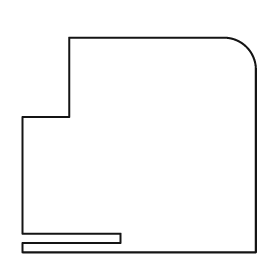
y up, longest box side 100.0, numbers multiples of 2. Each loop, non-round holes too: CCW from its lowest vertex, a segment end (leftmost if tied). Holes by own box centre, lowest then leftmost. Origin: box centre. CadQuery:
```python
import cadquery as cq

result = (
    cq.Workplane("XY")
    .moveTo(-50.0, -46.0)
    .lineTo(50.0, -46.0)
    .lineTo(50.0, 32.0)
    .threePointArc((46.0, 42.0), (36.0, 46.0))
    .lineTo(-30.0, 46.0)
    .lineTo(-30.0, 12.0)
    .lineTo(-50.0, 12.0)
    .lineTo(-50.0, -38.0)
    .lineTo(-8.0, -38.0)
    .lineTo(-8.0, -42.0)
    .lineTo(-50.0, -42.0)
    .close()
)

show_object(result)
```